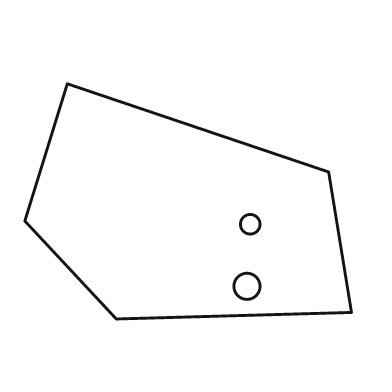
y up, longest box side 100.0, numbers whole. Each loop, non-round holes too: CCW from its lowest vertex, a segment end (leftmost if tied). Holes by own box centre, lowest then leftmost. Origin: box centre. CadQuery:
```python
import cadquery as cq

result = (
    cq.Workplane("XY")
    .moveTo(-22.0, -36.0)
    .lineTo(50.0, -34.0)
    .lineTo(43.0, 9.0)
    .lineTo(-37.0, 36.0)
    .lineTo(-50.0, -6.0)
    .close()
    .moveTo(18.0, -26.0)
    .circle(4.0)
    .moveTo(19.0, -7.0)
    .circle(3.0)
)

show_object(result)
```